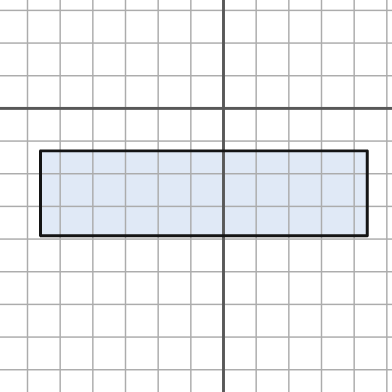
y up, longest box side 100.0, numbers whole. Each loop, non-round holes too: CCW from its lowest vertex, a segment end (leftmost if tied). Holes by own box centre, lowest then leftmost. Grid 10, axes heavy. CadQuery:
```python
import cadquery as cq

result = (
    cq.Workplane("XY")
    .moveTo(-56.0, -39.0)
    .lineTo(44.0, -39.0)
    .lineTo(44.0, -13.0)
    .lineTo(-56.0, -13.0)
    .close()
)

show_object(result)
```